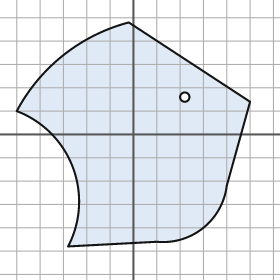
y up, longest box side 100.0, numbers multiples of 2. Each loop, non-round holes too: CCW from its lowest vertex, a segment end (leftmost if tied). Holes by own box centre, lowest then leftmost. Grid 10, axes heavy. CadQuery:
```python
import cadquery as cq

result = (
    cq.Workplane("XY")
    .moveTo(-28.0, -48.0)
    .lineTo(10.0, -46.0)
    .threePointArc((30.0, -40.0), (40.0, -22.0))
    .lineTo(50.0, 14.0)
    .lineTo(-2.0, 48.0)
    .threePointArc((-30.0, 34.0), (-50.0, 10.0))
    .threePointArc((-26.0, -14.0), (-28.0, -48.0))
    .close()
    .moveTo(22.0, 16.0)
    .circle(2.0)
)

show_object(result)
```